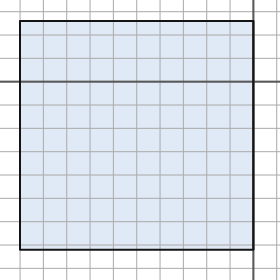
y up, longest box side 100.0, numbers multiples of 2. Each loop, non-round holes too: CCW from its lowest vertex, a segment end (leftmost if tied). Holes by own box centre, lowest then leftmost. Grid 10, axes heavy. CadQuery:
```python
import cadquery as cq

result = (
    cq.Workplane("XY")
    .moveTo(-100.0, -72.0)
    .lineTo(0.0, -72.0)
    .lineTo(0.0, 26.0)
    .lineTo(-100.0, 26.0)
    .close()
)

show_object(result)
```